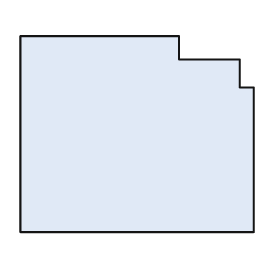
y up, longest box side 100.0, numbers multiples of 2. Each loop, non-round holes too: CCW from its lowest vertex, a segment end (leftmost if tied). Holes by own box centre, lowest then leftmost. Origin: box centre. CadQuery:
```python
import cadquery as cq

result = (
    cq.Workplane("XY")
    .moveTo(-50.0, -42.0)
    .lineTo(50.0, -42.0)
    .lineTo(50.0, 20.0)
    .lineTo(44.0, 20.0)
    .lineTo(44.0, 32.0)
    .lineTo(18.0, 32.0)
    .lineTo(18.0, 42.0)
    .lineTo(-50.0, 42.0)
    .close()
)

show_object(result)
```